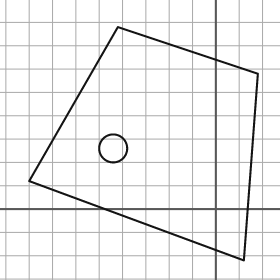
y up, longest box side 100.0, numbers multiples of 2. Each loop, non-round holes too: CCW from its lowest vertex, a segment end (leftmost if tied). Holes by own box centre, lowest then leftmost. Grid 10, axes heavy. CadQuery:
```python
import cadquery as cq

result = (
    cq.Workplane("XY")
    .moveTo(12.0, -22.0)
    .lineTo(18.0, 58.0)
    .lineTo(-42.0, 78.0)
    .lineTo(-80.0, 12.0)
    .close()
    .moveTo(-44.0, 26.0)
    .circle(6.0)
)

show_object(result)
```